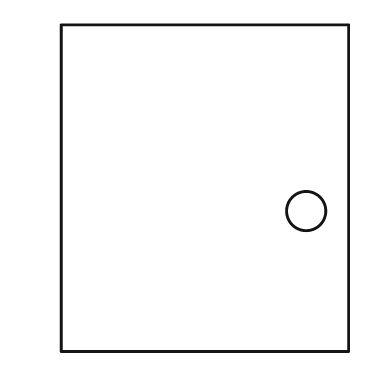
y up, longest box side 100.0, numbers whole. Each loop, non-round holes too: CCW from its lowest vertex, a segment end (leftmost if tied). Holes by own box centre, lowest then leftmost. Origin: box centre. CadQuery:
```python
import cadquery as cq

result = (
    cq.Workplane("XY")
    .moveTo(-44.0, -50.0)
    .lineTo(44.0, -50.0)
    .lineTo(44.0, 50.0)
    .lineTo(-44.0, 50.0)
    .close()
    .moveTo(31.0, -7.0)
    .circle(6.0)
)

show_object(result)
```